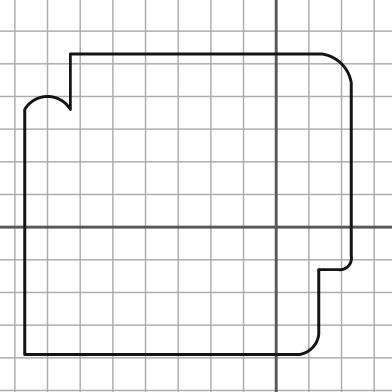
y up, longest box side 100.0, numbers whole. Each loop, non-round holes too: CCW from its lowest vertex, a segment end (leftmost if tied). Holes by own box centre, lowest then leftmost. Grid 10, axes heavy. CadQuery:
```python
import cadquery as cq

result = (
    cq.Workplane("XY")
    .moveTo(-77.0, -39.0)
    .lineTo(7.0, -39.0)
    .threePointArc((11.0, -37.0), (13.0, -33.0))
    .lineTo(13.0, -13.0)
    .lineTo(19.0, -13.0)
    .threePointArc((22.0, -12.0), (23.0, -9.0))
    .lineTo(23.0, 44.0)
    .threePointArc((20.0, 50.0), (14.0, 53.0))
    .lineTo(-63.0, 53.0)
    .lineTo(-63.0, 36.0)
    .threePointArc((-70.0, 40.0), (-77.0, 36.0))
    .close()
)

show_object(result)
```